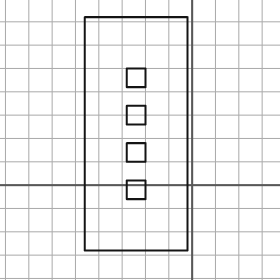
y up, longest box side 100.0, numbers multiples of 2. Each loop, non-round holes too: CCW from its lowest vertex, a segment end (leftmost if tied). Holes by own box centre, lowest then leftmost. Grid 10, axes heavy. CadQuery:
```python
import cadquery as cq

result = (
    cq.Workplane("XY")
    .moveTo(-46.0, -28.0)
    .lineTo(-2.0, -28.0)
    .lineTo(-2.0, 72.0)
    .lineTo(-46.0, 72.0)
    .close()
    .moveTo(-28.0, -6.0)
    .lineTo(-20.0, -6.0)
    .lineTo(-20.0, 2.0)
    .lineTo(-28.0, 2.0)
    .close()
    .moveTo(-28.0, 10.0)
    .lineTo(-20.0, 10.0)
    .lineTo(-20.0, 18.0)
    .lineTo(-28.0, 18.0)
    .close()
    .moveTo(-28.0, 26.0)
    .lineTo(-20.0, 26.0)
    .lineTo(-20.0, 34.0)
    .lineTo(-28.0, 34.0)
    .close()
    .moveTo(-28.0, 42.0)
    .lineTo(-20.0, 42.0)
    .lineTo(-20.0, 50.0)
    .lineTo(-28.0, 50.0)
    .close()
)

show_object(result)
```